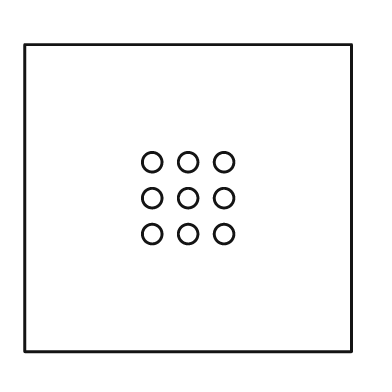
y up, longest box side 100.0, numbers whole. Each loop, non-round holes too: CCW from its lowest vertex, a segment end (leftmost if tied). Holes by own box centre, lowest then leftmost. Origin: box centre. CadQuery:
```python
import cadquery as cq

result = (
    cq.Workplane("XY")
    .moveTo(-50.0, -47.0)
    .lineTo(50.0, -47.0)
    .lineTo(50.0, 47.0)
    .lineTo(-50.0, 47.0)
    .close()
    .moveTo(-11.0, -11.0)
    .circle(3.0)
    .moveTo(0.0, -11.0)
    .circle(3.0)
    .moveTo(11.0, -11.0)
    .circle(3.0)
    .moveTo(-11.0, 0.0)
    .circle(3.0)
    .moveTo(0.0, 0.0)
    .circle(3.0)
    .moveTo(11.0, 0.0)
    .circle(3.0)
    .moveTo(-11.0, 11.0)
    .circle(3.0)
    .moveTo(0.0, 11.0)
    .circle(3.0)
    .moveTo(11.0, 11.0)
    .circle(3.0)
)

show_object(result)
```